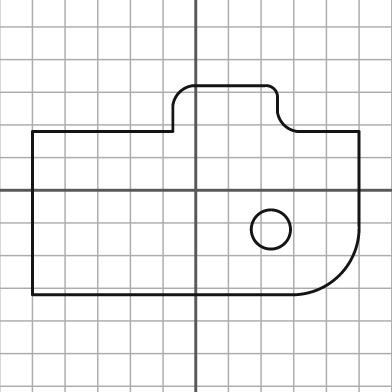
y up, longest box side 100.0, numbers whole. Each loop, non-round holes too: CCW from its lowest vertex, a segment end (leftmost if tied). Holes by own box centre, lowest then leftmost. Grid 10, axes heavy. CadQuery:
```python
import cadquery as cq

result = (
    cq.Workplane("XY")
    .moveTo(-50.0, -32.0)
    .lineTo(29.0, -32.0)
    .threePointArc((44.0, -26.0), (50.0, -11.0))
    .lineTo(50.0, 18.0)
    .lineTo(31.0, 18.0)
    .threePointArc((27.0, 20.0), (25.0, 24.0))
    .lineTo(25.0, 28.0)
    .threePointArc((24.0, 31.0), (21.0, 32.0))
    .lineTo(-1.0, 32.0)
    .threePointArc((-5.0, 30.0), (-7.0, 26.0))
    .lineTo(-7.0, 18.0)
    .lineTo(-50.0, 18.0)
    .close()
    .moveTo(23.0, -12.0)
    .circle(6.0)
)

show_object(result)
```